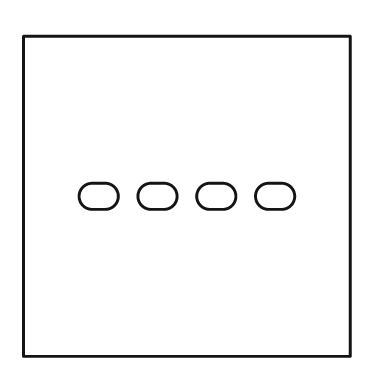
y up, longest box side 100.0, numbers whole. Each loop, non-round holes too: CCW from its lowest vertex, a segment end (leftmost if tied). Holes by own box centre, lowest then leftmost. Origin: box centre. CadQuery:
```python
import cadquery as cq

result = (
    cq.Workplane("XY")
    .moveTo(-50.0, -49.0)
    .lineTo(50.0, -49.0)
    .lineTo(50.0, 49.0)
    .lineTo(-50.0, 49.0)
    .close()
    .moveTo(-29.0, -4.0)
    .lineTo(-25.0, -4.0)
    .threePointArc((-21.0, 0.0), (-25.0, 4.0))
    .lineTo(-29.0, 4.0)
    .threePointArc((-33.0, 0.0), (-29.0, -4.0))
    .close()
    .moveTo(-11.0, -4.0)
    .lineTo(-7.0, -4.0)
    .threePointArc((-3.0, 0.0), (-7.0, 4.0))
    .lineTo(-11.0, 4.0)
    .threePointArc((-15.0, 0.0), (-11.0, -4.0))
    .close()
    .moveTo(7.0, -4.0)
    .lineTo(11.0, -4.0)
    .threePointArc((15.0, 0.0), (11.0, 4.0))
    .lineTo(7.0, 4.0)
    .threePointArc((3.0, 0.0), (7.0, -4.0))
    .close()
    .moveTo(25.0, -4.0)
    .lineTo(29.0, -4.0)
    .threePointArc((33.0, 0.0), (29.0, 4.0))
    .lineTo(25.0, 4.0)
    .threePointArc((21.0, 0.0), (25.0, -4.0))
    .close()
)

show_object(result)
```